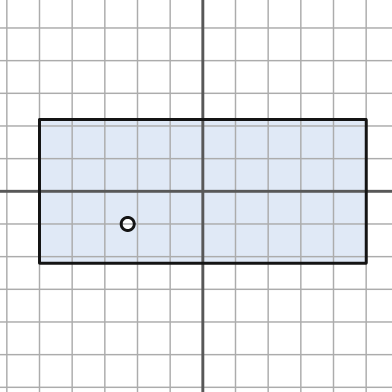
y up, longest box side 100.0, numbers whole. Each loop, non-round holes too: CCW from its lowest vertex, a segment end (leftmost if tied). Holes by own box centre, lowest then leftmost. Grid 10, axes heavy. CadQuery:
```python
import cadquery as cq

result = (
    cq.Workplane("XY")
    .moveTo(-50.0, -22.0)
    .lineTo(50.0, -22.0)
    .lineTo(50.0, 22.0)
    .lineTo(-50.0, 22.0)
    .close()
    .moveTo(-23.0, -10.0)
    .circle(2.0)
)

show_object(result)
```